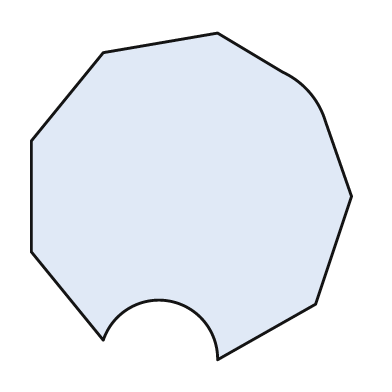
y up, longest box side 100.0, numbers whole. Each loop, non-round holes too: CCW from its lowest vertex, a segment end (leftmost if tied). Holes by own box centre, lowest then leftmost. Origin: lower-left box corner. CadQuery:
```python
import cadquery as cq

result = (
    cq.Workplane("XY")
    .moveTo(57.0, 0.0)
    .lineTo(87.0, 17.0)
    .lineTo(98.0, 50.0)
    .lineTo(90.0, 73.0)
    .threePointArc((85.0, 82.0), (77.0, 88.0))
    .lineTo(57.0, 100.0)
    .lineTo(22.0, 94.0)
    .lineTo(0.0, 67.0)
    .lineTo(0.0, 33.0)
    .lineTo(22.0, 6.0)
    .threePointArc((42.0, 18.0), (57.0, 0.0))
    .close()
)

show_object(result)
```